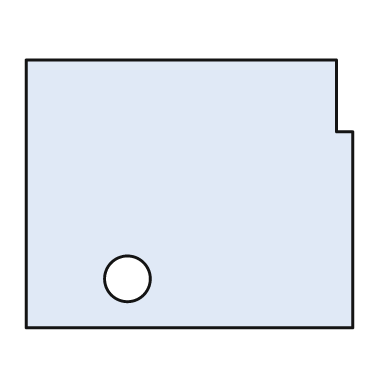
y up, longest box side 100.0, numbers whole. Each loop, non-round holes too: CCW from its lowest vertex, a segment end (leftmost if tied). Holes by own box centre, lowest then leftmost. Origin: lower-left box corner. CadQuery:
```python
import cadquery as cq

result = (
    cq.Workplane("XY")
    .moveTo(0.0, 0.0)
    .lineTo(100.0, 0.0)
    .lineTo(100.0, 60.0)
    .lineTo(95.0, 60.0)
    .lineTo(95.0, 82.0)
    .lineTo(0.0, 82.0)
    .close()
    .moveTo(31.0, 15.0)
    .circle(7.0)
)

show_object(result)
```